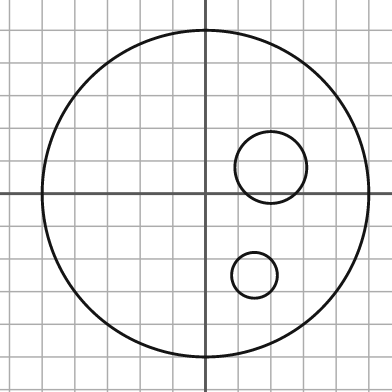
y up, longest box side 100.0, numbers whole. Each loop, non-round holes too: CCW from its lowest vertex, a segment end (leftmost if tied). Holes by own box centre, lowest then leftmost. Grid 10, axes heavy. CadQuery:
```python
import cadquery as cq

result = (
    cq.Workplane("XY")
    .moveTo(0.0, 0.0)
    .circle(50.0)
    .moveTo(15.0, -25.0)
    .circle(7.0)
    .moveTo(20.0, 8.0)
    .circle(11.0)
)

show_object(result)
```